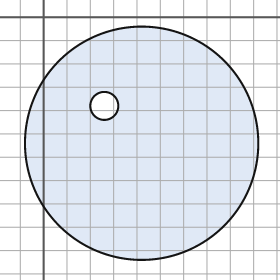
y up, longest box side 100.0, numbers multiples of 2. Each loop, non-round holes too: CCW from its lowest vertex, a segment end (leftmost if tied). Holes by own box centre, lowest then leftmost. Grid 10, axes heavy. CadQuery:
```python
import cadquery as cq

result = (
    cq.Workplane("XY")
    .moveTo(42.0, -54.0)
    .circle(50.0)
    .moveTo(26.0, -38.0)
    .circle(6.0)
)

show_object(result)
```